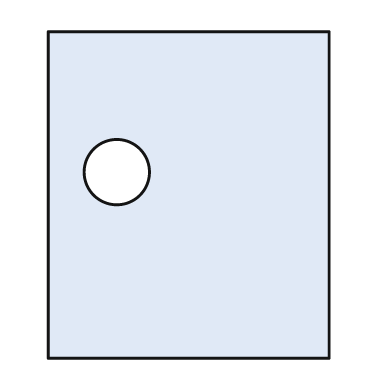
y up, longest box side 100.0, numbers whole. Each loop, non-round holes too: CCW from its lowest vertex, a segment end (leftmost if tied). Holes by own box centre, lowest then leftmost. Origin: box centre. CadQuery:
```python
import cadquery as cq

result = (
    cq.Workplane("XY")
    .moveTo(-43.0, -50.0)
    .lineTo(43.0, -50.0)
    .lineTo(43.0, 50.0)
    .lineTo(-43.0, 50.0)
    .close()
    .moveTo(-22.0, 7.0)
    .circle(10.0)
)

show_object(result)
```